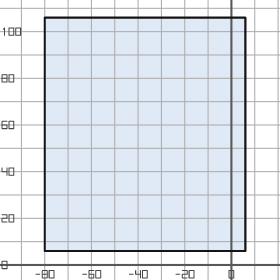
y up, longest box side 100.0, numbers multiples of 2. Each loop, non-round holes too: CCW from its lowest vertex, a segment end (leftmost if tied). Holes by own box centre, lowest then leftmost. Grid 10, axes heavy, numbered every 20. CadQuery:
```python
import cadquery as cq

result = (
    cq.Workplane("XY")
    .moveTo(-80.0, 6.0)
    .lineTo(6.0, 6.0)
    .lineTo(6.0, 106.0)
    .lineTo(-80.0, 106.0)
    .close()
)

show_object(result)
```